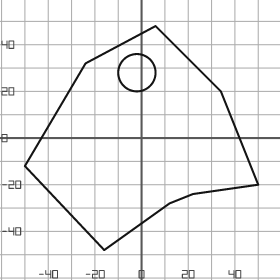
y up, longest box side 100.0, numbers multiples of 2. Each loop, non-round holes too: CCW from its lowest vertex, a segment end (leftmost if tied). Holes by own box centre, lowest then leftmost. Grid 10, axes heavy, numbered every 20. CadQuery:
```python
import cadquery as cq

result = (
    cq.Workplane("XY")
    .moveTo(-16.0, -48.0)
    .lineTo(12.0, -28.0)
    .lineTo(22.0, -24.0)
    .lineTo(50.0, -20.0)
    .lineTo(34.0, 20.0)
    .lineTo(6.0, 48.0)
    .lineTo(-24.0, 32.0)
    .lineTo(-50.0, -12.0)
    .close()
    .moveTo(-2.0, 28.0)
    .circle(8.0)
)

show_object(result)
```